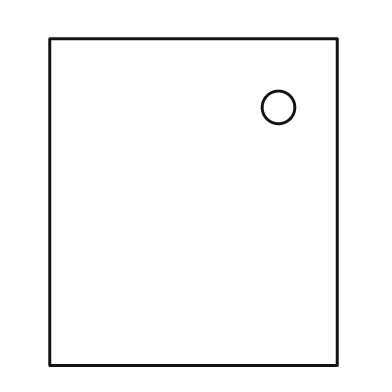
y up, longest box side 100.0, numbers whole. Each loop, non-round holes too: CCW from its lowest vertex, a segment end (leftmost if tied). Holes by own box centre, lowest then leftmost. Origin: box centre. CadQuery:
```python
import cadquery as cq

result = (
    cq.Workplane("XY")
    .moveTo(-44.0, -50.0)
    .lineTo(44.0, -50.0)
    .lineTo(44.0, 50.0)
    .lineTo(-44.0, 50.0)
    .close()
    .moveTo(26.0, 29.0)
    .circle(5.0)
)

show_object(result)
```